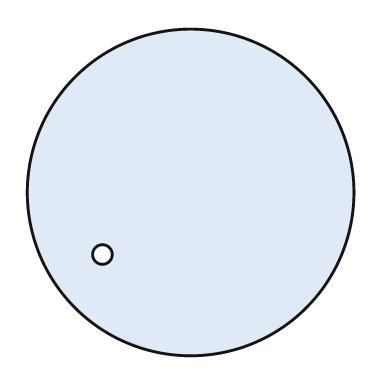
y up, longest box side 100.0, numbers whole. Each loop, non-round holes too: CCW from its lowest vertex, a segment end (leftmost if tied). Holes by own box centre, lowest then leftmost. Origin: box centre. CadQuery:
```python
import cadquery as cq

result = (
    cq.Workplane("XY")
    .moveTo(0.0, 0.0)
    .circle(50.0)
    .moveTo(-27.0, -19.0)
    .circle(3.0)
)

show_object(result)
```